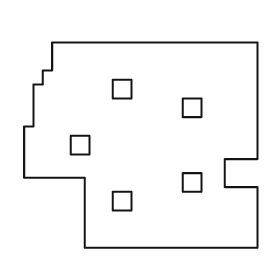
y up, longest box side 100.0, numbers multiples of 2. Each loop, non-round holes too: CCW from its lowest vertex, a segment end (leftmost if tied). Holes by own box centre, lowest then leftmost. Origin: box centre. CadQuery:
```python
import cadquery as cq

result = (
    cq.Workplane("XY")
    .moveTo(-24.0, -44.0)
    .lineTo(50.0, -44.0)
    .lineTo(50.0, -18.0)
    .lineTo(36.0, -18.0)
    .lineTo(36.0, -6.0)
    .lineTo(50.0, -6.0)
    .lineTo(50.0, 44.0)
    .lineTo(-38.0, 44.0)
    .lineTo(-38.0, 32.0)
    .lineTo(-42.0, 32.0)
    .lineTo(-42.0, 26.0)
    .lineTo(-46.0, 26.0)
    .lineTo(-46.0, 8.0)
    .lineTo(-50.0, 8.0)
    .lineTo(-50.0, -14.0)
    .lineTo(-24.0, -14.0)
    .close()
    .moveTo(-12.0, -28.0)
    .lineTo(-4.0, -28.0)
    .lineTo(-4.0, -20.0)
    .lineTo(-12.0, -20.0)
    .close()
    .moveTo(18.0, -20.0)
    .lineTo(26.0, -20.0)
    .lineTo(26.0, -12.0)
    .lineTo(18.0, -12.0)
    .close()
    .moveTo(-30.0, -4.0)
    .lineTo(-22.0, -4.0)
    .lineTo(-22.0, 4.0)
    .lineTo(-30.0, 4.0)
    .close()
    .moveTo(18.0, 12.0)
    .lineTo(26.0, 12.0)
    .lineTo(26.0, 20.0)
    .lineTo(18.0, 20.0)
    .close()
    .moveTo(-12.0, 20.0)
    .lineTo(-4.0, 20.0)
    .lineTo(-4.0, 28.0)
    .lineTo(-12.0, 28.0)
    .close()
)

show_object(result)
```